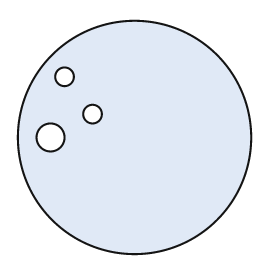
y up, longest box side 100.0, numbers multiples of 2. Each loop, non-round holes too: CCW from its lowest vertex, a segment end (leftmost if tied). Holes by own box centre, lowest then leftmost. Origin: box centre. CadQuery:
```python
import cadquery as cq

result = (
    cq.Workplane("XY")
    .moveTo(0.0, 0.0)
    .circle(50.0)
    .moveTo(-36.0, 0.0)
    .circle(6.0)
    .moveTo(-18.0, 10.0)
    .circle(4.0)
    .moveTo(-30.0, 26.0)
    .circle(4.0)
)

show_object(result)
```